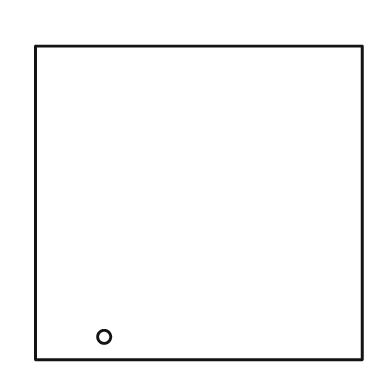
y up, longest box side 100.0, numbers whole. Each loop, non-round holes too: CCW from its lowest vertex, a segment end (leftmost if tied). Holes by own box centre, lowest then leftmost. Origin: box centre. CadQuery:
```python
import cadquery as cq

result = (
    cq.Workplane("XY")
    .moveTo(-50.0, -48.0)
    .lineTo(50.0, -48.0)
    .lineTo(50.0, 48.0)
    .lineTo(-50.0, 48.0)
    .close()
    .moveTo(-29.0, -41.0)
    .circle(2.0)
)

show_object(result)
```